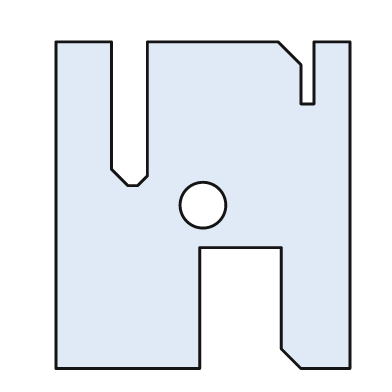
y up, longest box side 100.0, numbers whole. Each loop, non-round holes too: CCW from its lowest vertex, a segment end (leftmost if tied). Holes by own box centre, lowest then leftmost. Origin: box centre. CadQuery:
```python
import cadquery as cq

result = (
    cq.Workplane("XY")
    .moveTo(-45.0, -50.0)
    .lineTo(-1.0, -50.0)
    .lineTo(-1.0, -13.0)
    .lineTo(24.0, -13.0)
    .lineTo(24.0, -44.0)
    .lineTo(30.0, -50.0)
    .lineTo(45.0, -50.0)
    .lineTo(45.0, 50.0)
    .lineTo(34.0, 50.0)
    .lineTo(34.0, 31.0)
    .lineTo(30.0, 31.0)
    .lineTo(30.0, 43.0)
    .lineTo(23.0, 50.0)
    .lineTo(-17.0, 50.0)
    .lineTo(-17.0, 9.0)
    .lineTo(-20.0, 6.0)
    .lineTo(-23.0, 6.0)
    .lineTo(-28.0, 11.0)
    .lineTo(-28.0, 50.0)
    .lineTo(-45.0, 50.0)
    .close()
    .moveTo(0.0, 0.0)
    .circle(7.0)
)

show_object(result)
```